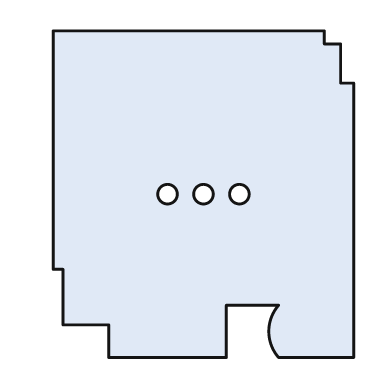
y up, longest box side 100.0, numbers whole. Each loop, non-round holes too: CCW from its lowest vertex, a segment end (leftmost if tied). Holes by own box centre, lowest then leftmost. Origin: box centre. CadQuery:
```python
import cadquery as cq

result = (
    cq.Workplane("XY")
    .moveTo(-29.0, -50.0)
    .lineTo(7.0, -50.0)
    .lineTo(7.0, -34.0)
    .lineTo(23.0, -34.0)
    .threePointArc((20.0, -42.0), (23.0, -50.0))
    .lineTo(46.0, -50.0)
    .lineTo(46.0, 34.0)
    .lineTo(42.0, 34.0)
    .lineTo(42.0, 46.0)
    .lineTo(37.0, 46.0)
    .lineTo(37.0, 50.0)
    .lineTo(-46.0, 50.0)
    .lineTo(-46.0, -23.0)
    .lineTo(-43.0, -23.0)
    .lineTo(-43.0, -40.0)
    .lineTo(-29.0, -40.0)
    .close()
    .moveTo(-11.0, 0.0)
    .circle(3.0)
    .moveTo(0.0, 0.0)
    .circle(3.0)
    .moveTo(11.0, 0.0)
    .circle(3.0)
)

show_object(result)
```